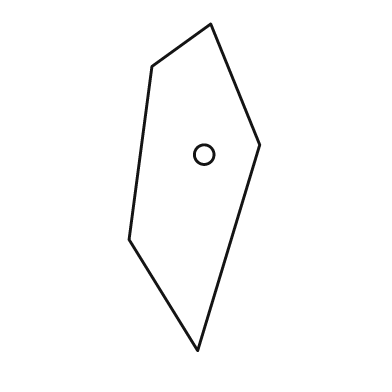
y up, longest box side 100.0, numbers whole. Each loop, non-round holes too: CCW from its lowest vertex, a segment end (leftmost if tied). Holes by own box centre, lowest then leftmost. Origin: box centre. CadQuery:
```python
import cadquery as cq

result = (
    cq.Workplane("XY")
    .moveTo(1.0, -50.0)
    .lineTo(20.0, 13.0)
    .lineTo(5.0, 50.0)
    .lineTo(-13.0, 37.0)
    .lineTo(-20.0, -16.0)
    .close()
    .moveTo(3.0, 10.0)
    .circle(3.0)
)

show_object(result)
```